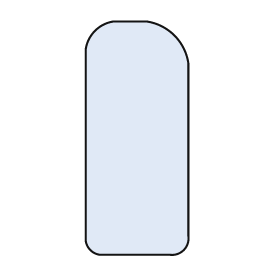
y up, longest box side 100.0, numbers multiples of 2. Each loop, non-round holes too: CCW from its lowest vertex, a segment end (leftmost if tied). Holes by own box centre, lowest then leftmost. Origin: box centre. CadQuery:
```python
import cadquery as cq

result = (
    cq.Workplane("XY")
    .moveTo(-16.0, -50.0)
    .lineTo(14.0, -50.0)
    .threePointArc((20.0, -48.0), (22.0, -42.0))
    .lineTo(22.0, 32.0)
    .threePointArc((16.0, 44.0), (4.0, 50.0))
    .lineTo(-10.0, 50.0)
    .threePointArc((-18.0, 46.0), (-22.0, 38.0))
    .lineTo(-22.0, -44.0)
    .threePointArc((-20.0, -48.0), (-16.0, -50.0))
    .close()
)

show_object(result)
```